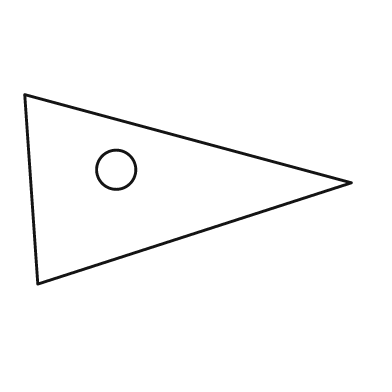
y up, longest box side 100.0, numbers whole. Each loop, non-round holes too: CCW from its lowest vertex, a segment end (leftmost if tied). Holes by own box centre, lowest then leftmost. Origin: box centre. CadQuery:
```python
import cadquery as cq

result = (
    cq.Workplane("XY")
    .moveTo(-46.0, -29.0)
    .lineTo(50.0, 2.0)
    .lineTo(-50.0, 29.0)
    .close()
    .moveTo(-22.0, 6.0)
    .circle(6.0)
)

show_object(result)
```